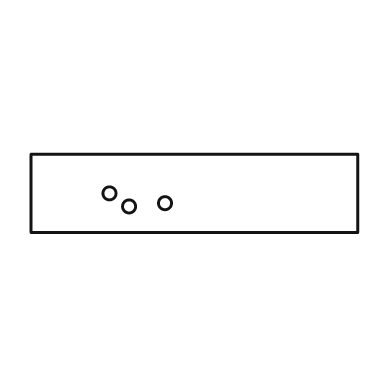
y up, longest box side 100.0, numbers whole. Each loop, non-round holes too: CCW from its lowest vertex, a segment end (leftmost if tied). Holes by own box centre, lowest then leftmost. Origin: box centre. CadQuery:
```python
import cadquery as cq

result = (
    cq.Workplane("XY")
    .moveTo(-50.0, -12.0)
    .lineTo(50.0, -12.0)
    .lineTo(50.0, 12.0)
    .lineTo(-50.0, 12.0)
    .close()
    .moveTo(-20.0, -4.0)
    .circle(2.0)
    .moveTo(-9.0, -3.0)
    .circle(2.0)
    .moveTo(-26.0, 0.0)
    .circle(2.0)
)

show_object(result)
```